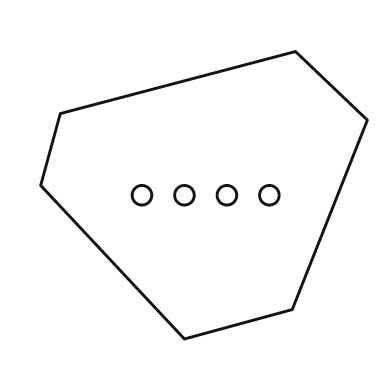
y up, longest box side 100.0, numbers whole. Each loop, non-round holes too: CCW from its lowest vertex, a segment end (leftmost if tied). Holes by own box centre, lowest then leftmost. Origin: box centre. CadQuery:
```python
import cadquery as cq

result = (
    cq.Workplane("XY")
    .moveTo(-6.0, -44.0)
    .lineTo(27.0, -35.0)
    .lineTo(50.0, 23.0)
    .lineTo(28.0, 44.0)
    .lineTo(-44.0, 25.0)
    .lineTo(-50.0, 3.0)
    .close()
    .moveTo(-19.0, 0.0)
    .circle(3.0)
    .moveTo(-6.0, 0.0)
    .circle(3.0)
    .moveTo(7.0, 0.0)
    .circle(3.0)
    .moveTo(20.0, 0.0)
    .circle(3.0)
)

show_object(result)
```